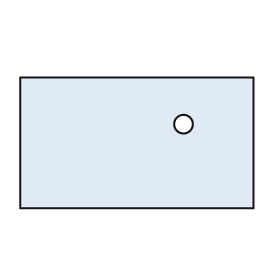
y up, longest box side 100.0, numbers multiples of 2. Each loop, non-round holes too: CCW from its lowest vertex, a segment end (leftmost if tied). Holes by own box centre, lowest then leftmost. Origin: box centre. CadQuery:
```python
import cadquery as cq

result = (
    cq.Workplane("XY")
    .moveTo(-50.0, -28.0)
    .lineTo(50.0, -28.0)
    .lineTo(50.0, 28.0)
    .lineTo(-50.0, 28.0)
    .close()
    .moveTo(20.0, 8.0)
    .circle(4.0)
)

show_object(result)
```